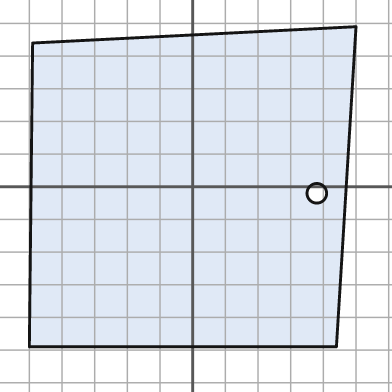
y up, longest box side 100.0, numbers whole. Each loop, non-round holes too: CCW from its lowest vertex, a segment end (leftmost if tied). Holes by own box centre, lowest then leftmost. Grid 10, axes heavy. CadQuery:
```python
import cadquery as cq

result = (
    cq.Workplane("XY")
    .moveTo(-50.0, -49.0)
    .lineTo(44.0, -49.0)
    .lineTo(50.0, 49.0)
    .lineTo(-49.0, 44.0)
    .close()
    .moveTo(38.0, -2.0)
    .circle(3.0)
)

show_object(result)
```